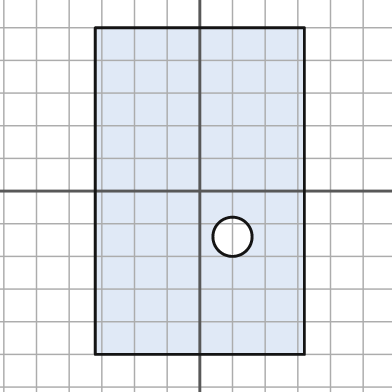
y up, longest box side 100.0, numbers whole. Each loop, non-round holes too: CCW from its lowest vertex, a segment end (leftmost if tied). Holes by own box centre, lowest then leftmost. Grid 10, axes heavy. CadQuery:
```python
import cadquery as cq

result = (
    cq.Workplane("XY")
    .moveTo(-32.0, -50.0)
    .lineTo(32.0, -50.0)
    .lineTo(32.0, 50.0)
    .lineTo(-32.0, 50.0)
    .close()
    .moveTo(10.0, -14.0)
    .circle(6.0)
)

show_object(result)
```